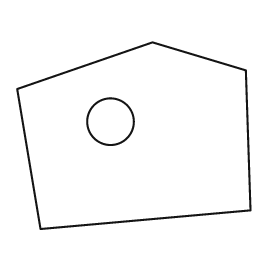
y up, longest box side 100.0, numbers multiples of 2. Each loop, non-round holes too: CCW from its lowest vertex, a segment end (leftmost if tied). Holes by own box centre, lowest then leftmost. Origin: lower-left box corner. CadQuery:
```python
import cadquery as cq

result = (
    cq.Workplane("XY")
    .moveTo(10.0, 0.0)
    .lineTo(100.0, 8.0)
    .lineTo(98.0, 68.0)
    .lineTo(58.0, 80.0)
    .lineTo(0.0, 60.0)
    .close()
    .moveTo(40.0, 46.0)
    .circle(10.0)
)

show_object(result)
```